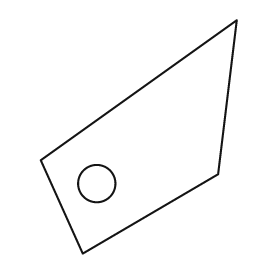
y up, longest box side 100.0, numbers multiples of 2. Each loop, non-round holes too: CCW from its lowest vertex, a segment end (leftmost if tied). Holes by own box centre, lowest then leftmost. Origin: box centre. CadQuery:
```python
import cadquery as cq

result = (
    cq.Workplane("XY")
    .moveTo(-24.0, -50.0)
    .lineTo(34.0, -16.0)
    .lineTo(42.0, 50.0)
    .lineTo(-42.0, -10.0)
    .close()
    .moveTo(-18.0, -20.0)
    .circle(8.0)
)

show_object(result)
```